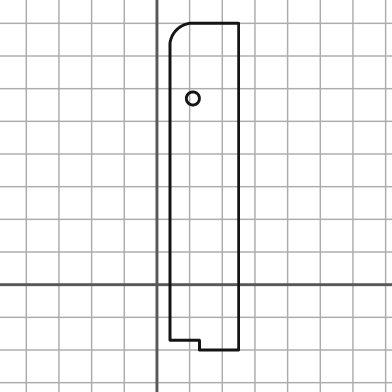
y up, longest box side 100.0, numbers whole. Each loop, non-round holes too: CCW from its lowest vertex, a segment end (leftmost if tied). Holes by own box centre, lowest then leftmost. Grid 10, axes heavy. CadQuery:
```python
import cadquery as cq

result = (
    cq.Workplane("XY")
    .moveTo(13.0, -20.0)
    .lineTo(25.0, -20.0)
    .lineTo(25.0, 80.0)
    .lineTo(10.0, 80.0)
    .threePointArc((6.0, 78.0), (4.0, 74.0))
    .lineTo(4.0, -17.0)
    .lineTo(13.0, -17.0)
    .close()
    .moveTo(11.0, 57.0)
    .circle(2.0)
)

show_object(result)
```